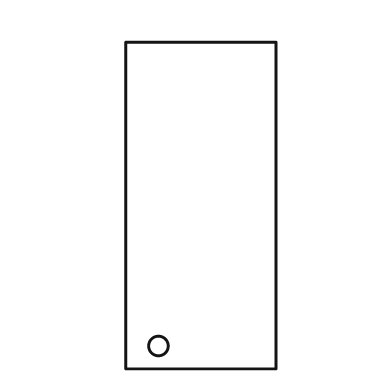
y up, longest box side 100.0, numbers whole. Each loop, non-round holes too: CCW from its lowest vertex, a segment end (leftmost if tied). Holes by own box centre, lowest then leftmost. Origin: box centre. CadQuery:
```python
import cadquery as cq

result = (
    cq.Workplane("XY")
    .moveTo(-23.0, -50.0)
    .lineTo(23.0, -50.0)
    .lineTo(23.0, 50.0)
    .lineTo(-23.0, 50.0)
    .close()
    .moveTo(-13.0, -43.0)
    .circle(3.0)
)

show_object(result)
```